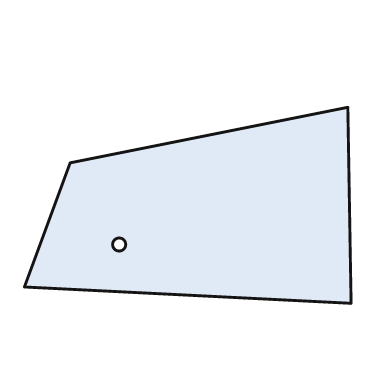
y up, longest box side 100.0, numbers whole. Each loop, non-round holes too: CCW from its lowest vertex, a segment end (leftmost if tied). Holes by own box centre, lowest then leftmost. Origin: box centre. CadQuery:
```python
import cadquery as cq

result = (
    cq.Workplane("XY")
    .moveTo(50.0, -30.0)
    .lineTo(49.0, 30.0)
    .lineTo(-36.0, 13.0)
    .lineTo(-50.0, -25.0)
    .close()
    .moveTo(-21.0, -12.0)
    .circle(2.0)
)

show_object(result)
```